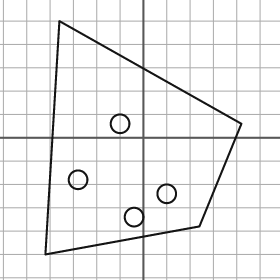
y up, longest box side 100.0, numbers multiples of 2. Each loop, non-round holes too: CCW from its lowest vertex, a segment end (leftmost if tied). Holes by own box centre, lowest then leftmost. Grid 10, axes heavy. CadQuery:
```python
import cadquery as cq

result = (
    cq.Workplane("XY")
    .moveTo(-42.0, -50.0)
    .lineTo(24.0, -38.0)
    .lineTo(42.0, 6.0)
    .lineTo(-36.0, 50.0)
    .close()
    .moveTo(-4.0, -34.0)
    .circle(4.0)
    .moveTo(10.0, -24.0)
    .circle(4.0)
    .moveTo(-28.0, -18.0)
    .circle(4.0)
    .moveTo(-10.0, 6.0)
    .circle(4.0)
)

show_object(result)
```